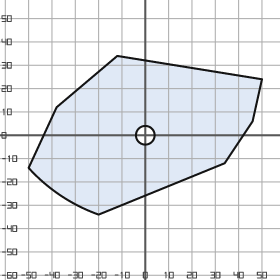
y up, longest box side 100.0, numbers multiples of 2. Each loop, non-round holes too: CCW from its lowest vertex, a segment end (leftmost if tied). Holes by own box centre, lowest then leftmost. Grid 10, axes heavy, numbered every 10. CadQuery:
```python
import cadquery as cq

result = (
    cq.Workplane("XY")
    .moveTo(-20.0, -34.0)
    .lineTo(34.0, -12.0)
    .lineTo(46.0, 6.0)
    .lineTo(50.0, 24.0)
    .lineTo(-12.0, 34.0)
    .lineTo(-38.0, 12.0)
    .lineTo(-50.0, -14.0)
    .threePointArc((-36.0, -26.0), (-20.0, -34.0))
    .close()
    .moveTo(0.0, 0.0)
    .circle(4.0)
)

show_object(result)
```